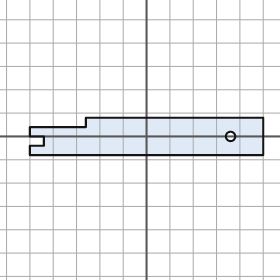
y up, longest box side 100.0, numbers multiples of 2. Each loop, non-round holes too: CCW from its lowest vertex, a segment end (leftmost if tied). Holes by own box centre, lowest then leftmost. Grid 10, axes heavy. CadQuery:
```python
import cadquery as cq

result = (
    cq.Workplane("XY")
    .moveTo(-50.0, -8.0)
    .lineTo(50.0, -8.0)
    .lineTo(50.0, 8.0)
    .lineTo(-26.0, 8.0)
    .lineTo(-26.0, 4.0)
    .lineTo(-50.0, 4.0)
    .lineTo(-50.0, 0.0)
    .lineTo(-44.0, 0.0)
    .lineTo(-44.0, -4.0)
    .lineTo(-50.0, -4.0)
    .close()
    .moveTo(36.0, 0.0)
    .circle(2.0)
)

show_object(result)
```